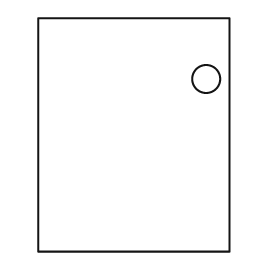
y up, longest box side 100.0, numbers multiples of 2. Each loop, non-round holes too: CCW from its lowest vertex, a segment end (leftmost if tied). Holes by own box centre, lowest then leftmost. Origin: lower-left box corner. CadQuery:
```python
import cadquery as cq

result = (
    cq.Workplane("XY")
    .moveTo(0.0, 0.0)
    .lineTo(82.0, 0.0)
    .lineTo(82.0, 100.0)
    .lineTo(0.0, 100.0)
    .close()
    .moveTo(72.0, 74.0)
    .circle(6.0)
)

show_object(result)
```